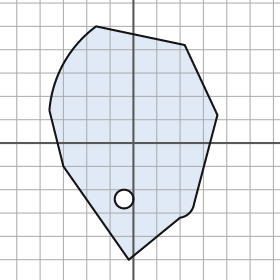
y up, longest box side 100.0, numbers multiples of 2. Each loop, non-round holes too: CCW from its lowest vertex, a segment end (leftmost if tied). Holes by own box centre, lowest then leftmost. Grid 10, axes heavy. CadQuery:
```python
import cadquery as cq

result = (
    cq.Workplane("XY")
    .moveTo(-2.0, -50.0)
    .lineTo(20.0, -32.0)
    .threePointArc((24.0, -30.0), (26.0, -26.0))
    .lineTo(36.0, 12.0)
    .lineTo(22.0, 42.0)
    .lineTo(-16.0, 50.0)
    .threePointArc((-30.0, 34.0), (-36.0, 14.0))
    .lineTo(-30.0, -10.0)
    .close()
    .moveTo(-4.0, -24.0)
    .circle(4.0)
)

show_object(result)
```